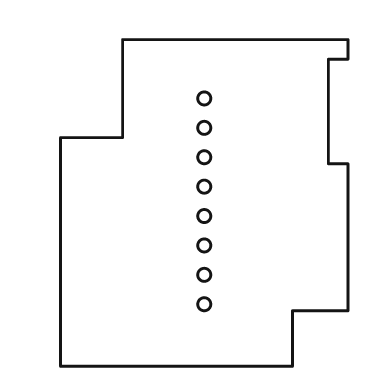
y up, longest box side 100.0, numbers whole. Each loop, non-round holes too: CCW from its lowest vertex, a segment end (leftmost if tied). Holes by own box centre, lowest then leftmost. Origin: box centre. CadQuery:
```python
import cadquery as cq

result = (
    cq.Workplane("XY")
    .moveTo(-44.0, -50.0)
    .lineTo(27.0, -50.0)
    .lineTo(27.0, -33.0)
    .lineTo(44.0, -33.0)
    .lineTo(44.0, 12.0)
    .lineTo(38.0, 12.0)
    .lineTo(38.0, 44.0)
    .lineTo(44.0, 44.0)
    .lineTo(44.0, 50.0)
    .lineTo(-25.0, 50.0)
    .lineTo(-25.0, 20.0)
    .lineTo(-44.0, 20.0)
    .close()
    .moveTo(0.0, -31.0)
    .circle(2.0)
    .moveTo(0.0, -22.0)
    .circle(2.0)
    .moveTo(0.0, -13.0)
    .circle(2.0)
    .moveTo(0.0, -4.0)
    .circle(2.0)
    .moveTo(0.0, 5.0)
    .circle(2.0)
    .moveTo(0.0, 14.0)
    .circle(2.0)
    .moveTo(0.0, 23.0)
    .circle(2.0)
    .moveTo(0.0, 32.0)
    .circle(2.0)
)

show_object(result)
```